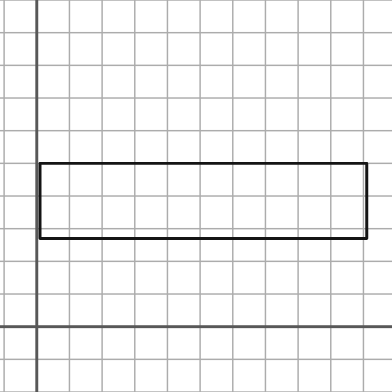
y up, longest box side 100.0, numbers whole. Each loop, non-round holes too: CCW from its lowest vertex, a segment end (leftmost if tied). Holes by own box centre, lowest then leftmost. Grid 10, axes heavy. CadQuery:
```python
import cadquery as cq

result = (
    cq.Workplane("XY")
    .moveTo(1.0, 27.0)
    .lineTo(101.0, 27.0)
    .lineTo(101.0, 50.0)
    .lineTo(1.0, 50.0)
    .close()
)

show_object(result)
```